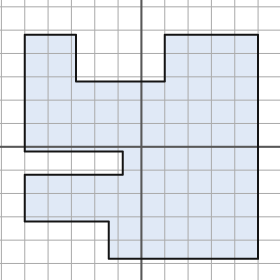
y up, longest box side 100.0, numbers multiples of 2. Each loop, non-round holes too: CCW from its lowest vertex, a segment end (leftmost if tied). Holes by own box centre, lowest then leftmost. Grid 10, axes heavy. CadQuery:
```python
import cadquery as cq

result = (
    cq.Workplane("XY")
    .moveTo(-14.0, -48.0)
    .lineTo(50.0, -48.0)
    .lineTo(50.0, 48.0)
    .lineTo(10.0, 48.0)
    .lineTo(10.0, 28.0)
    .lineTo(-28.0, 28.0)
    .lineTo(-28.0, 48.0)
    .lineTo(-50.0, 48.0)
    .lineTo(-50.0, -2.0)
    .lineTo(-8.0, -2.0)
    .lineTo(-8.0, -12.0)
    .lineTo(-50.0, -12.0)
    .lineTo(-50.0, -32.0)
    .lineTo(-14.0, -32.0)
    .close()
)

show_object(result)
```